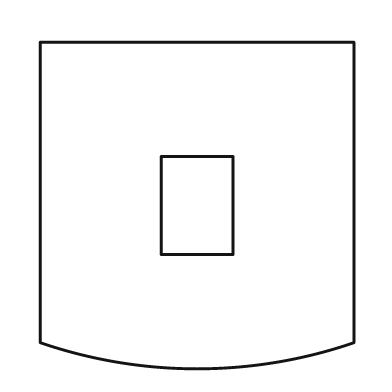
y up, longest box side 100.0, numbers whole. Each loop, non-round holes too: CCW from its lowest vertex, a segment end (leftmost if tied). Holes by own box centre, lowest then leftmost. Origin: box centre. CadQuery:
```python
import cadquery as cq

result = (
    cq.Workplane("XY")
    .moveTo(-48.0, -42.0)
    .threePointArc((0.0, -50.0), (48.0, -42.0))
    .lineTo(48.0, 50.0)
    .lineTo(-48.0, 50.0)
    .close()
    .moveTo(-11.0, -15.0)
    .lineTo(11.0, -15.0)
    .lineTo(11.0, 15.0)
    .lineTo(-11.0, 15.0)
    .close()
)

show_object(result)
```